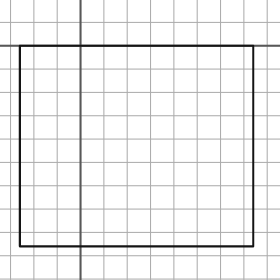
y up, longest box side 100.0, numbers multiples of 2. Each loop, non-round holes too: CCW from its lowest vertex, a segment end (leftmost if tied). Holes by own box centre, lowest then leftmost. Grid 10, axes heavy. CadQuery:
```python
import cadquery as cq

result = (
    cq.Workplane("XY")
    .moveTo(-26.0, -86.0)
    .lineTo(74.0, -86.0)
    .lineTo(74.0, 0.0)
    .lineTo(-26.0, 0.0)
    .close()
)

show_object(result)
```